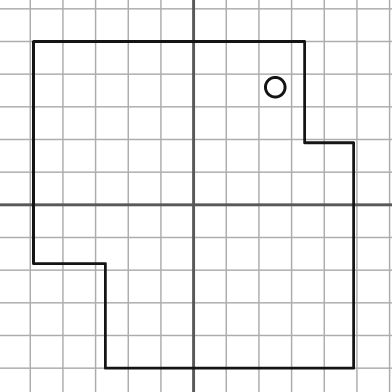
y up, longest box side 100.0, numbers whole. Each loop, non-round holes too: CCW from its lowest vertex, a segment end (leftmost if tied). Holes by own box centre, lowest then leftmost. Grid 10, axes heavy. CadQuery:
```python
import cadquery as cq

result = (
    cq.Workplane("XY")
    .moveTo(-27.0, -50.0)
    .lineTo(49.0, -50.0)
    .lineTo(49.0, 19.0)
    .lineTo(34.0, 19.0)
    .lineTo(34.0, 50.0)
    .lineTo(-49.0, 50.0)
    .lineTo(-49.0, -18.0)
    .lineTo(-27.0, -18.0)
    .close()
    .moveTo(25.0, 36.0)
    .circle(3.0)
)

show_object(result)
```